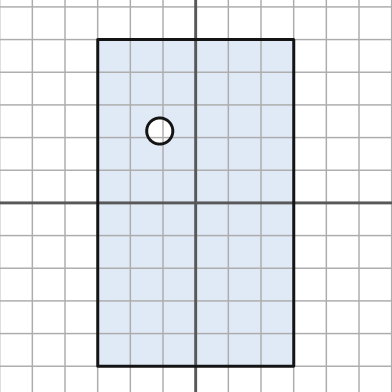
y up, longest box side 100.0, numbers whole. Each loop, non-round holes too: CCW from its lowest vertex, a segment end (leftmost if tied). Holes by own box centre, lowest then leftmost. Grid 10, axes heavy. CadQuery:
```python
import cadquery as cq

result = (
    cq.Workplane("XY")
    .moveTo(-30.0, -50.0)
    .lineTo(30.0, -50.0)
    .lineTo(30.0, 50.0)
    .lineTo(-30.0, 50.0)
    .close()
    .moveTo(-11.0, 22.0)
    .circle(4.0)
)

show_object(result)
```